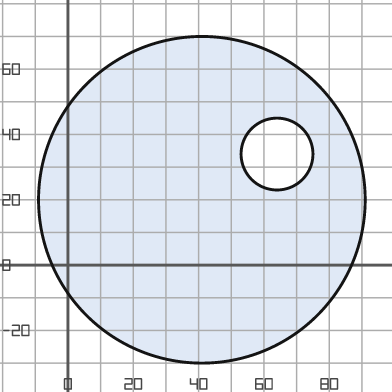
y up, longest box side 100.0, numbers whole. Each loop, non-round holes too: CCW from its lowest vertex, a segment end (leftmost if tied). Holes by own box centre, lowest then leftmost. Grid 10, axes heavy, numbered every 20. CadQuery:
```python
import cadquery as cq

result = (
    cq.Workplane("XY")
    .moveTo(41.0, 20.0)
    .circle(50.0)
    .moveTo(64.0, 34.0)
    .circle(11.0)
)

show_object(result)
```